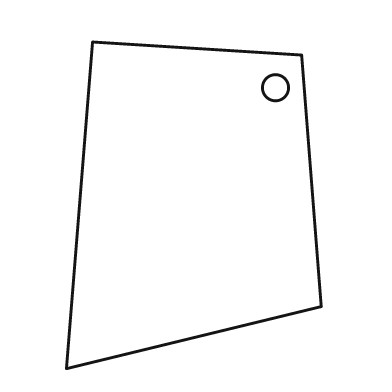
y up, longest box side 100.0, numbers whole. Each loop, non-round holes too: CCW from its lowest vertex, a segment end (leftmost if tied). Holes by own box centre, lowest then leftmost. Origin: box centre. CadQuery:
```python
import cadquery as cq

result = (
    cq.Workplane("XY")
    .moveTo(-39.0, -50.0)
    .lineTo(39.0, -31.0)
    .lineTo(33.0, 46.0)
    .lineTo(-31.0, 50.0)
    .close()
    .moveTo(25.0, 36.0)
    .circle(4.0)
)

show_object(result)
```